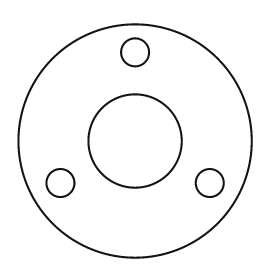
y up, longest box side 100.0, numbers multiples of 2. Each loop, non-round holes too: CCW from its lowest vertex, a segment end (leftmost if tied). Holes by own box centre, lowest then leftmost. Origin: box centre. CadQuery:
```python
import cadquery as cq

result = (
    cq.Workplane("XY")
    .moveTo(0.0, 0.0)
    .circle(50.0)
    .moveTo(-32.0, -18.0)
    .circle(6.0)
    .moveTo(32.0, -18.0)
    .circle(6.0)
    .moveTo(0.0, 0.0)
    .circle(20.0)
    .moveTo(0.0, 38.0)
    .circle(6.0)
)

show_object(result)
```